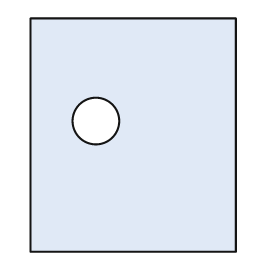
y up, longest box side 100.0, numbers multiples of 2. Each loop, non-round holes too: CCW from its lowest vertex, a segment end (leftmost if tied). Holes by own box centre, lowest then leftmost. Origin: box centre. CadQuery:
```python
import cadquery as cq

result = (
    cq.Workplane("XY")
    .moveTo(-44.0, -50.0)
    .lineTo(44.0, -50.0)
    .lineTo(44.0, 50.0)
    .lineTo(-44.0, 50.0)
    .close()
    .moveTo(-16.0, 6.0)
    .circle(10.0)
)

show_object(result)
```